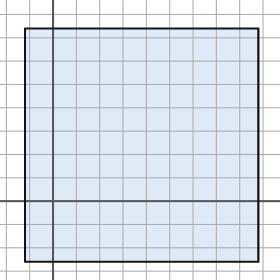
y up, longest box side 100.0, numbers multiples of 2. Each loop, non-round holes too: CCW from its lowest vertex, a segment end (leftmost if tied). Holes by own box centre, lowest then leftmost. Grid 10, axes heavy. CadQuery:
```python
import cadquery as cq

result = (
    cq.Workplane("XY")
    .moveTo(-12.0, -26.0)
    .lineTo(88.0, -26.0)
    .lineTo(88.0, 74.0)
    .lineTo(-12.0, 74.0)
    .close()
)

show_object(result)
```